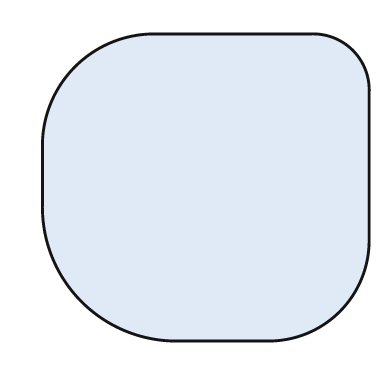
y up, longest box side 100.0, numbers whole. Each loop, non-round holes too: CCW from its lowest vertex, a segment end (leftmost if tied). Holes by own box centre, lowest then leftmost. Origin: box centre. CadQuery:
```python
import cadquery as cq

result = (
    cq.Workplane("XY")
    .moveTo(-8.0, -47.0)
    .lineTo(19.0, -47.0)
    .threePointArc((41.0, -38.0), (50.0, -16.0))
    .lineTo(50.0, 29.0)
    .threePointArc((45.0, 42.0), (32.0, 47.0))
    .lineTo(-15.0, 47.0)
    .threePointArc((-40.0, 37.0), (-50.0, 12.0))
    .lineTo(-50.0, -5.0)
    .threePointArc((-38.0, -35.0), (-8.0, -47.0))
    .close()
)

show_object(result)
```